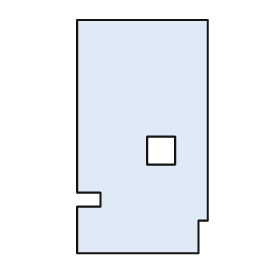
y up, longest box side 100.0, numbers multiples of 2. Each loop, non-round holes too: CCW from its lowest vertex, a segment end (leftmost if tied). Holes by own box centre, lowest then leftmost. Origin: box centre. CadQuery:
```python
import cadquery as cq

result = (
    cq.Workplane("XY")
    .moveTo(-28.0, -50.0)
    .lineTo(24.0, -50.0)
    .lineTo(24.0, -36.0)
    .lineTo(28.0, -36.0)
    .lineTo(28.0, 50.0)
    .lineTo(-28.0, 50.0)
    .lineTo(-28.0, -24.0)
    .lineTo(-18.0, -24.0)
    .lineTo(-18.0, -30.0)
    .lineTo(-28.0, -30.0)
    .close()
    .moveTo(2.0, -12.0)
    .lineTo(14.0, -12.0)
    .lineTo(14.0, 0.0)
    .lineTo(2.0, 0.0)
    .close()
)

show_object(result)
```